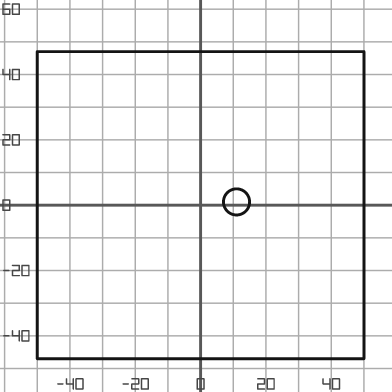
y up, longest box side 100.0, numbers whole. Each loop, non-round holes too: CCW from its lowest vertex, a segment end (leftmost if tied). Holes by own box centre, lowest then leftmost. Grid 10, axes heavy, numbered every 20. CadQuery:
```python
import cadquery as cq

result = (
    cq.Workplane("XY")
    .moveTo(-50.0, -47.0)
    .lineTo(50.0, -47.0)
    .lineTo(50.0, 47.0)
    .lineTo(-50.0, 47.0)
    .close()
    .moveTo(11.0, 1.0)
    .circle(4.0)
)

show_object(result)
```